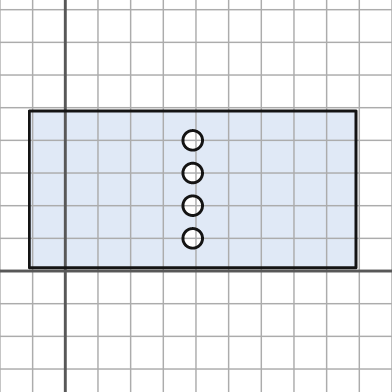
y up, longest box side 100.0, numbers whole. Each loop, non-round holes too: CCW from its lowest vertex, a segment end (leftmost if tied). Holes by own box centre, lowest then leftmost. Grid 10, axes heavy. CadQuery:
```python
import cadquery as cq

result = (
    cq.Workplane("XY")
    .moveTo(-11.0, 1.0)
    .lineTo(89.0, 1.0)
    .lineTo(89.0, 49.0)
    .lineTo(-11.0, 49.0)
    .close()
    .moveTo(39.0, 10.0)
    .circle(3.0)
    .moveTo(39.0, 20.0)
    .circle(3.0)
    .moveTo(39.0, 30.0)
    .circle(3.0)
    .moveTo(39.0, 40.0)
    .circle(3.0)
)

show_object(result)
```